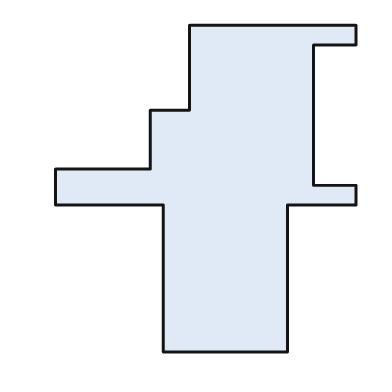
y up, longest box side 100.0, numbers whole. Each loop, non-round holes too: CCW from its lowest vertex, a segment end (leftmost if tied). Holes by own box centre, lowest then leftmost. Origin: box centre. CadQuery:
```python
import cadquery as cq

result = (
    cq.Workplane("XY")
    .moveTo(-13.0, -50.0)
    .lineTo(25.0, -50.0)
    .lineTo(25.0, -5.0)
    .lineTo(46.0, -5.0)
    .lineTo(46.0, 1.0)
    .lineTo(33.0, 1.0)
    .lineTo(33.0, 44.0)
    .lineTo(46.0, 44.0)
    .lineTo(46.0, 50.0)
    .lineTo(-5.0, 50.0)
    .lineTo(-5.0, 24.0)
    .lineTo(-17.0, 24.0)
    .lineTo(-17.0, 6.0)
    .lineTo(-46.0, 6.0)
    .lineTo(-46.0, -5.0)
    .lineTo(-13.0, -5.0)
    .close()
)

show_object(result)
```